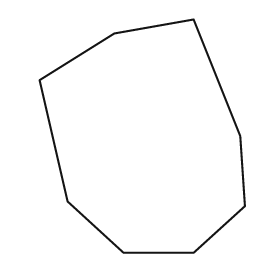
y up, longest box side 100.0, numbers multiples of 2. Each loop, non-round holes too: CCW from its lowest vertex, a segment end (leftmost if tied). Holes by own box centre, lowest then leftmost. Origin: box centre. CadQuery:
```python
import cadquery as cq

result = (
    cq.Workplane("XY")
    .moveTo(-8.0, -50.0)
    .lineTo(22.0, -50.0)
    .lineTo(44.0, -30.0)
    .lineTo(42.0, 0.0)
    .lineTo(22.0, 50.0)
    .lineTo(-12.0, 44.0)
    .lineTo(-44.0, 24.0)
    .lineTo(-32.0, -28.0)
    .close()
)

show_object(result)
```